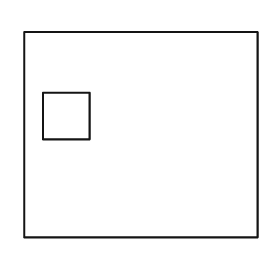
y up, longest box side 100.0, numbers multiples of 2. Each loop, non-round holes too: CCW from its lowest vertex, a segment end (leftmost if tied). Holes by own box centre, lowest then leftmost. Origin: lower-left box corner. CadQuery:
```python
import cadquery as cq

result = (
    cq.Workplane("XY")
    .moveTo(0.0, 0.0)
    .lineTo(100.0, 0.0)
    .lineTo(100.0, 88.0)
    .lineTo(0.0, 88.0)
    .close()
    .moveTo(8.0, 42.0)
    .lineTo(28.0, 42.0)
    .lineTo(28.0, 62.0)
    .lineTo(8.0, 62.0)
    .close()
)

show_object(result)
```